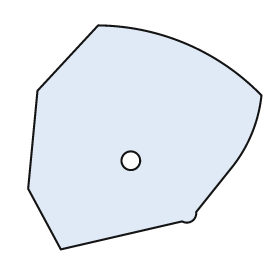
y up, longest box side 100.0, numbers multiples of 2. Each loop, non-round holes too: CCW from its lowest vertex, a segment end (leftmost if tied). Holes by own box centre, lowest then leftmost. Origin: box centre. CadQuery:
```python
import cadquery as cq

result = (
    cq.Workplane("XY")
    .moveTo(-36.0, -48.0)
    .lineTo(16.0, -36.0)
    .threePointArc((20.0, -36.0), (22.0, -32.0))
    .lineTo(38.0, -12.0)
    .threePointArc((46.0, 2.0), (50.0, 18.0))
    .threePointArc((18.0, 40.0), (-20.0, 48.0))
    .lineTo(-46.0, 20.0)
    .lineTo(-50.0, -22.0)
    .close()
    .moveTo(-6.0, -10.0)
    .circle(4.0)
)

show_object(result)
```